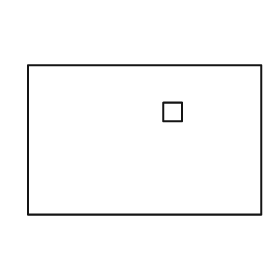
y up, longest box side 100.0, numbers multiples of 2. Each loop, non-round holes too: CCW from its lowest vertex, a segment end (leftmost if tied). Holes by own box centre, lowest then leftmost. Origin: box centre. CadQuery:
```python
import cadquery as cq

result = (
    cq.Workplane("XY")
    .moveTo(-50.0, -32.0)
    .lineTo(50.0, -32.0)
    .lineTo(50.0, 32.0)
    .lineTo(-50.0, 32.0)
    .close()
    .moveTo(8.0, 8.0)
    .lineTo(16.0, 8.0)
    .lineTo(16.0, 16.0)
    .lineTo(8.0, 16.0)
    .close()
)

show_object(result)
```